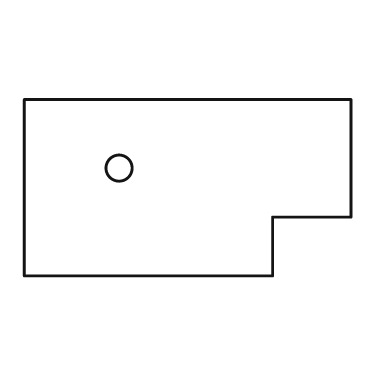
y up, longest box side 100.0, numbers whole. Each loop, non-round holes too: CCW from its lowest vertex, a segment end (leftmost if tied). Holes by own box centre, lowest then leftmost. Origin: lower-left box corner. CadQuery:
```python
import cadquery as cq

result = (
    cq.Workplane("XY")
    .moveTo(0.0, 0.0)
    .lineTo(76.0, 0.0)
    .lineTo(76.0, 18.0)
    .lineTo(100.0, 18.0)
    .lineTo(100.0, 54.0)
    .lineTo(0.0, 54.0)
    .close()
    .moveTo(29.0, 33.0)
    .circle(4.0)
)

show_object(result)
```